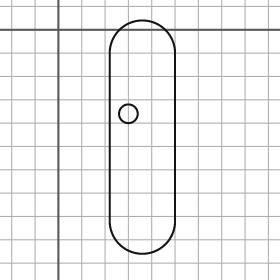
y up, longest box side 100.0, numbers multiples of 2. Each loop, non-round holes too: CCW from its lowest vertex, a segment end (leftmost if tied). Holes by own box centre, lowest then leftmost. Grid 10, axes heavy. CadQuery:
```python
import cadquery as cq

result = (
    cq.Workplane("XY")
    .moveTo(22.0, -82.0)
    .threePointArc((36.0, -96.0), (50.0, -82.0))
    .lineTo(50.0, -10.0)
    .threePointArc((36.0, 4.0), (22.0, -10.0))
    .close()
    .moveTo(30.0, -36.0)
    .circle(4.0)
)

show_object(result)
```